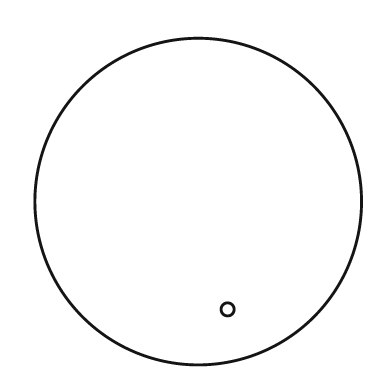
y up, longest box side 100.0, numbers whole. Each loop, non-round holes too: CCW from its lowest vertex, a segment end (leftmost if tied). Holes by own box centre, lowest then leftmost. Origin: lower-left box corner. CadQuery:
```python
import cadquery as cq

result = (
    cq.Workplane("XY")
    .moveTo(50.0, 50.0)
    .circle(50.0)
    .moveTo(59.0, 17.0)
    .circle(2.0)
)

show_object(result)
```